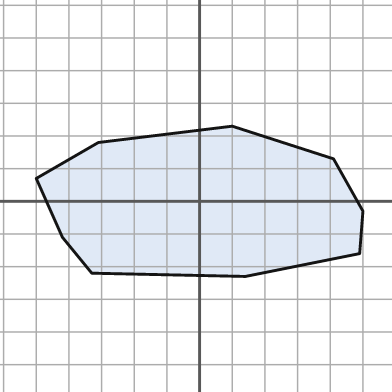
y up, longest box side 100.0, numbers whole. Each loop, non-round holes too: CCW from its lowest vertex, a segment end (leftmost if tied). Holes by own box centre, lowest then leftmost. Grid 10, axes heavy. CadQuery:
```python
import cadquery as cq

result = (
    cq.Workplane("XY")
    .moveTo(14.0, -23.0)
    .lineTo(49.0, -16.0)
    .lineTo(50.0, -3.0)
    .lineTo(41.0, 13.0)
    .lineTo(10.0, 23.0)
    .lineTo(-31.0, 18.0)
    .lineTo(-50.0, 7.0)
    .lineTo(-42.0, -11.0)
    .lineTo(-33.0, -22.0)
    .close()
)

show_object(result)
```